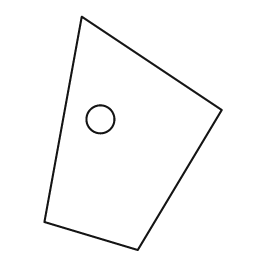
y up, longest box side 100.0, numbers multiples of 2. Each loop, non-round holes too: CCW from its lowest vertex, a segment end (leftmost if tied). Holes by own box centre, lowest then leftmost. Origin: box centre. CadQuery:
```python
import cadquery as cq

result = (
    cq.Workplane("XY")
    .moveTo(2.0, -50.0)
    .lineTo(38.0, 10.0)
    .lineTo(-22.0, 50.0)
    .lineTo(-38.0, -38.0)
    .close()
    .moveTo(-14.0, 6.0)
    .circle(6.0)
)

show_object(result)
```